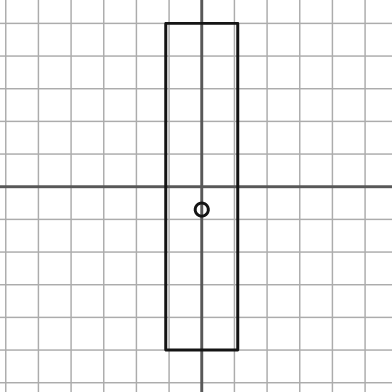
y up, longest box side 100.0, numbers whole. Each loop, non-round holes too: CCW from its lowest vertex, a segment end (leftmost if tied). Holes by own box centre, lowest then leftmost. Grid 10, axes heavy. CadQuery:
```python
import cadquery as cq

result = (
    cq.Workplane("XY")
    .moveTo(-11.0, -50.0)
    .lineTo(11.0, -50.0)
    .lineTo(11.0, 50.0)
    .lineTo(-11.0, 50.0)
    .close()
    .moveTo(0.0, -7.0)
    .circle(2.0)
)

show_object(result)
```